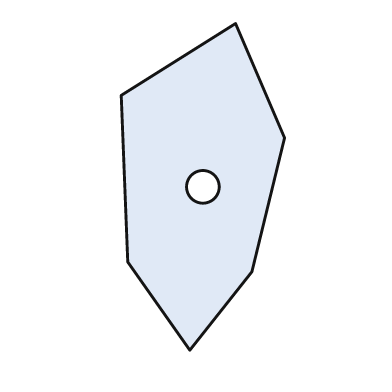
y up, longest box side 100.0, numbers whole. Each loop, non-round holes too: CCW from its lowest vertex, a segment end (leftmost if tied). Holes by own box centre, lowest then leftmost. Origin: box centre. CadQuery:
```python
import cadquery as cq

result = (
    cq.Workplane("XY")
    .moveTo(-4.0, -50.0)
    .lineTo(15.0, -26.0)
    .lineTo(25.0, 15.0)
    .lineTo(10.0, 50.0)
    .lineTo(-25.0, 28.0)
    .lineTo(-23.0, -23.0)
    .close()
    .moveTo(0.0, 0.0)
    .circle(5.0)
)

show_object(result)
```